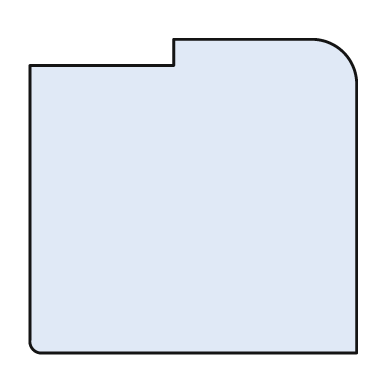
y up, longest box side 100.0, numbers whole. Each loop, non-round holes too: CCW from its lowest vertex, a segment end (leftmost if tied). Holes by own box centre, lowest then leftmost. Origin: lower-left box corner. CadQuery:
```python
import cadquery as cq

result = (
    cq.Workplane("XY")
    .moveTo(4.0, 0.0)
    .lineTo(100.0, 0.0)
    .lineTo(100.0, 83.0)
    .threePointArc((96.0, 92.0), (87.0, 96.0))
    .lineTo(44.0, 96.0)
    .lineTo(44.0, 88.0)
    .lineTo(0.0, 88.0)
    .lineTo(0.0, 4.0)
    .threePointArc((1.0, 1.0), (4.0, 0.0))
    .close()
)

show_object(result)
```